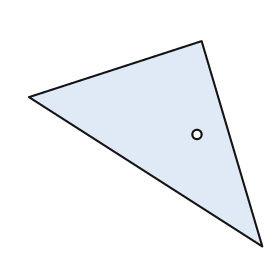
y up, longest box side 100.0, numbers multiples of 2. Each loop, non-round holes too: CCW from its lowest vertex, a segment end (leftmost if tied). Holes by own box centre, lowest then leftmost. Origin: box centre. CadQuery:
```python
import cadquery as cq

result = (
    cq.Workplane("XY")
    .moveTo(50.0, -44.0)
    .lineTo(24.0, 44.0)
    .lineTo(-50.0, 20.0)
    .close()
    .moveTo(22.0, 4.0)
    .circle(2.0)
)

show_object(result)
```